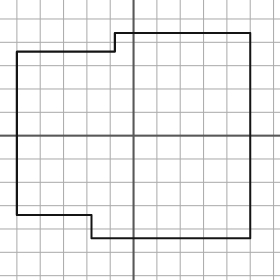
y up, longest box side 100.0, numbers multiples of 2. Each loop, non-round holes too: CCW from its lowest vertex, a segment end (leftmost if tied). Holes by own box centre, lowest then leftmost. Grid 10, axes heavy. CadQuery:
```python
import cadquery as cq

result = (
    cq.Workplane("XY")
    .moveTo(-18.0, -44.0)
    .lineTo(50.0, -44.0)
    .lineTo(50.0, 44.0)
    .lineTo(-8.0, 44.0)
    .lineTo(-8.0, 36.0)
    .lineTo(-50.0, 36.0)
    .lineTo(-50.0, -34.0)
    .lineTo(-18.0, -34.0)
    .close()
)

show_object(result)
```